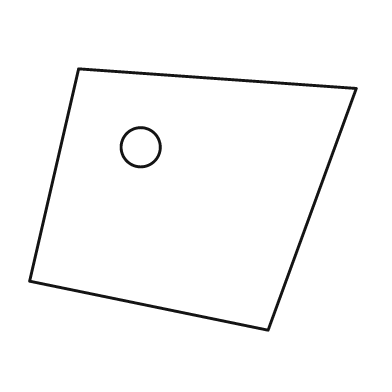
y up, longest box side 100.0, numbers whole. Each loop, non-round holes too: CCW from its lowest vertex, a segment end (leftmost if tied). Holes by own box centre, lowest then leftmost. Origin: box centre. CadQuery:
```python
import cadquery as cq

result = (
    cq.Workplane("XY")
    .moveTo(23.0, -40.0)
    .lineTo(50.0, 34.0)
    .lineTo(-35.0, 40.0)
    .lineTo(-50.0, -25.0)
    .close()
    .moveTo(-16.0, 16.0)
    .circle(6.0)
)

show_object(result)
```